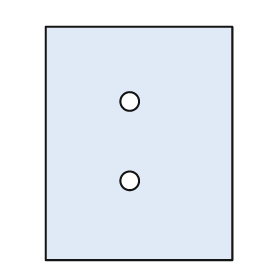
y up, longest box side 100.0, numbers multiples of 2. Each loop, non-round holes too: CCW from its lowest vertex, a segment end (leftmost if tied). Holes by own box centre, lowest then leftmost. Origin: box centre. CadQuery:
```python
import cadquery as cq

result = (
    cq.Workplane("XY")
    .moveTo(-40.0, -50.0)
    .lineTo(40.0, -50.0)
    .lineTo(40.0, 50.0)
    .lineTo(-40.0, 50.0)
    .close()
    .moveTo(-4.0, -16.0)
    .circle(4.0)
    .moveTo(-4.0, 18.0)
    .circle(4.0)
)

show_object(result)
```